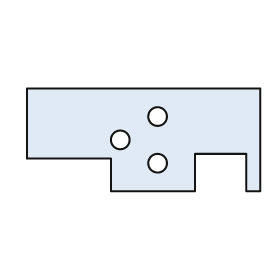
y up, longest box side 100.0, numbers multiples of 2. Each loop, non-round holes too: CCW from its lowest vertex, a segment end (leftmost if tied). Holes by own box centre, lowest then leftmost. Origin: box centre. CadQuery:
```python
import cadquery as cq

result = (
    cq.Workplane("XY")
    .moveTo(-14.0, -22.0)
    .lineTo(22.0, -22.0)
    .lineTo(22.0, -6.0)
    .lineTo(44.0, -6.0)
    .lineTo(44.0, -22.0)
    .lineTo(50.0, -22.0)
    .lineTo(50.0, 22.0)
    .lineTo(-50.0, 22.0)
    .lineTo(-50.0, -8.0)
    .lineTo(-14.0, -8.0)
    .close()
    .moveTo(6.0, -10.0)
    .circle(4.0)
    .moveTo(-10.0, 0.0)
    .circle(4.0)
    .moveTo(6.0, 10.0)
    .circle(4.0)
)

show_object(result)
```